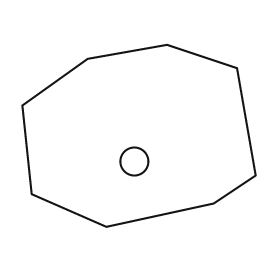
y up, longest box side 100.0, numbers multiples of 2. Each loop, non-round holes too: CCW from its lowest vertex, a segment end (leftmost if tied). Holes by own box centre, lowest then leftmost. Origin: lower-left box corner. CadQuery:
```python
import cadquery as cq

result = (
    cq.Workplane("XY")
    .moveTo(36.0, 0.0)
    .lineTo(82.0, 10.0)
    .lineTo(100.0, 22.0)
    .lineTo(92.0, 68.0)
    .lineTo(62.0, 78.0)
    .lineTo(28.0, 72.0)
    .lineTo(0.0, 52.0)
    .lineTo(4.0, 14.0)
    .close()
    .moveTo(48.0, 28.0)
    .circle(6.0)
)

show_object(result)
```